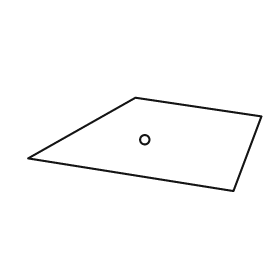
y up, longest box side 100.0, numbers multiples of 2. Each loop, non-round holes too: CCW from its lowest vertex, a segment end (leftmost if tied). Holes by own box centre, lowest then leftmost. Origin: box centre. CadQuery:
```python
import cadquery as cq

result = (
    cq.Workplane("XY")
    .moveTo(38.0, -20.0)
    .lineTo(50.0, 12.0)
    .lineTo(-4.0, 20.0)
    .lineTo(-50.0, -6.0)
    .close()
    .moveTo(0.0, 2.0)
    .circle(2.0)
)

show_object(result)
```